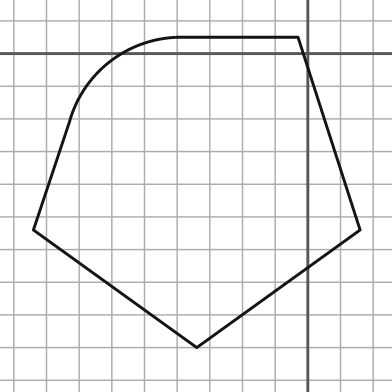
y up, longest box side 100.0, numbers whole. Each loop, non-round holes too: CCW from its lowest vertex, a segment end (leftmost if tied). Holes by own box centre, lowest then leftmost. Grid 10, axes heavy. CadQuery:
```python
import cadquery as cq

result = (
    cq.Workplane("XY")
    .moveTo(-34.0, -90.0)
    .lineTo(16.0, -54.0)
    .lineTo(-3.0, 5.0)
    .lineTo(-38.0, 5.0)
    .threePointArc((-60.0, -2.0), (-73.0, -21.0))
    .lineTo(-84.0, -54.0)
    .close()
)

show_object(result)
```